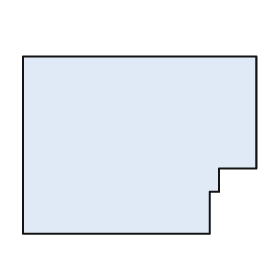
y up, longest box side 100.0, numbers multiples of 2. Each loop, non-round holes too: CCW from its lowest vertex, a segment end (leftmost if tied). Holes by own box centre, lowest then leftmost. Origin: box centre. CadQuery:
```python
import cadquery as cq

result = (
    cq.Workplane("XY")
    .moveTo(-50.0, -38.0)
    .lineTo(30.0, -38.0)
    .lineTo(30.0, -20.0)
    .lineTo(34.0, -20.0)
    .lineTo(34.0, -10.0)
    .lineTo(50.0, -10.0)
    .lineTo(50.0, 38.0)
    .lineTo(-50.0, 38.0)
    .close()
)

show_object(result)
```